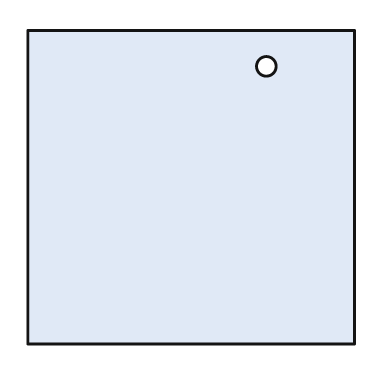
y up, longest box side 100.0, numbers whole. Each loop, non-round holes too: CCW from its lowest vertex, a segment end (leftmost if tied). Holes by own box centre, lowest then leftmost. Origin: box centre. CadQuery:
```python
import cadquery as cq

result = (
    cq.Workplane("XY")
    .moveTo(-50.0, -48.0)
    .lineTo(50.0, -48.0)
    .lineTo(50.0, 48.0)
    .lineTo(-50.0, 48.0)
    .close()
    .moveTo(23.0, 37.0)
    .circle(3.0)
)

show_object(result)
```